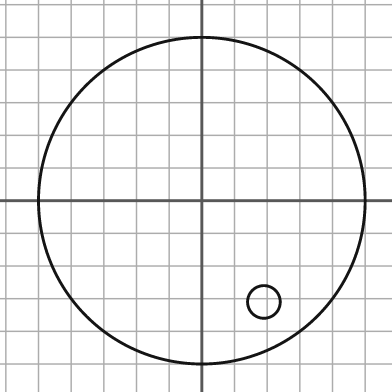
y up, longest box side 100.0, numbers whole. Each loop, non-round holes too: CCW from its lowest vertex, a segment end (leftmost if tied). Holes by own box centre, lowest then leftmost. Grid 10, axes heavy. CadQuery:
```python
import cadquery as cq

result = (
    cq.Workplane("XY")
    .moveTo(0.0, 0.0)
    .circle(50.0)
    .moveTo(19.0, -31.0)
    .circle(5.0)
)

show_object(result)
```